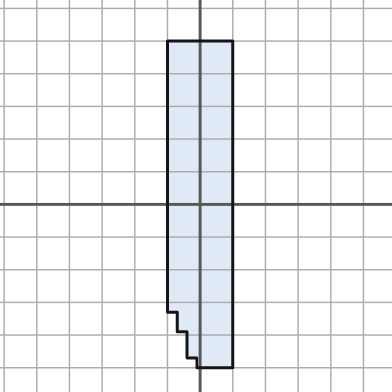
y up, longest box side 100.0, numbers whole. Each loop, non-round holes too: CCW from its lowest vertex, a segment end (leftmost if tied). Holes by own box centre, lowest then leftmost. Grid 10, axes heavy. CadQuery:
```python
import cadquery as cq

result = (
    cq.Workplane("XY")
    .moveTo(-1.0, -50.0)
    .lineTo(10.0, -50.0)
    .lineTo(10.0, 50.0)
    .lineTo(-10.0, 50.0)
    .lineTo(-10.0, -33.0)
    .lineTo(-7.0, -33.0)
    .lineTo(-7.0, -39.0)
    .lineTo(-4.0, -39.0)
    .lineTo(-4.0, -47.0)
    .lineTo(-1.0, -47.0)
    .close()
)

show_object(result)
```